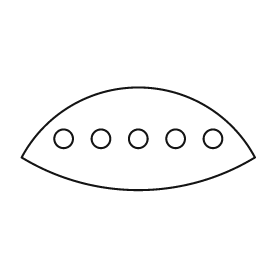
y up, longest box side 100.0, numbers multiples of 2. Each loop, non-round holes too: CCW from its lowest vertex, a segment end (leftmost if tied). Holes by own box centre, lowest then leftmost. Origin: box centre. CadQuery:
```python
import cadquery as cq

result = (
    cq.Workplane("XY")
    .moveTo(-50.0, -8.0)
    .threePointArc((0.0, -22.0), (50.0, -8.0))
    .threePointArc((0.0, 22.0), (-50.0, -8.0))
    .close()
    .moveTo(-32.0, 0.0)
    .circle(4.0)
    .moveTo(-16.0, 0.0)
    .circle(4.0)
    .moveTo(0.0, 0.0)
    .circle(4.0)
    .moveTo(16.0, 0.0)
    .circle(4.0)
    .moveTo(32.0, 0.0)
    .circle(4.0)
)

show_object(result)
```